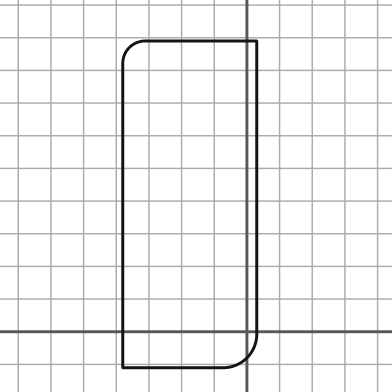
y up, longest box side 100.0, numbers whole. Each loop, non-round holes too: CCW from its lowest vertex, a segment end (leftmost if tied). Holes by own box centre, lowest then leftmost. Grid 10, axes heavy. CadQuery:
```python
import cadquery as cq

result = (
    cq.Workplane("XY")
    .moveTo(-38.0, -11.0)
    .lineTo(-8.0, -11.0)
    .threePointArc((0.0, -8.0), (3.0, 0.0))
    .lineTo(3.0, 89.0)
    .lineTo(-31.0, 89.0)
    .threePointArc((-36.0, 87.0), (-38.0, 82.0))
    .close()
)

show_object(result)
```